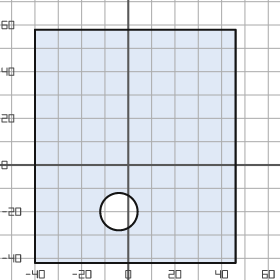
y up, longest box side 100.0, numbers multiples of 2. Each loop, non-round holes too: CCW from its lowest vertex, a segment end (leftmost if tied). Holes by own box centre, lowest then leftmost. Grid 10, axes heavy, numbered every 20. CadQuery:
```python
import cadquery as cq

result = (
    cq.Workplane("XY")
    .moveTo(-40.0, -42.0)
    .lineTo(46.0, -42.0)
    .lineTo(46.0, 58.0)
    .lineTo(-40.0, 58.0)
    .close()
    .moveTo(-4.0, -20.0)
    .circle(8.0)
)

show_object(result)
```